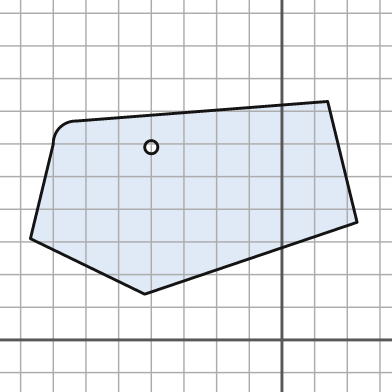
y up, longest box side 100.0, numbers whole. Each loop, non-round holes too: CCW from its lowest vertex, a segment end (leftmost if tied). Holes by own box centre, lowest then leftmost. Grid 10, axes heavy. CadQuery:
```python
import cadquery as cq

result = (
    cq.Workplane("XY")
    .moveTo(-42.0, 14.0)
    .lineTo(23.0, 36.0)
    .lineTo(14.0, 73.0)
    .lineTo(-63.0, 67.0)
    .threePointArc((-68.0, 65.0), (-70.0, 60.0))
    .lineTo(-77.0, 31.0)
    .close()
    .moveTo(-40.0, 59.0)
    .circle(2.0)
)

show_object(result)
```